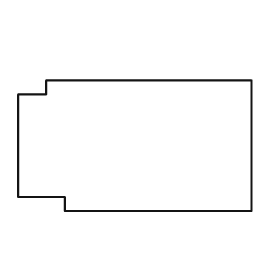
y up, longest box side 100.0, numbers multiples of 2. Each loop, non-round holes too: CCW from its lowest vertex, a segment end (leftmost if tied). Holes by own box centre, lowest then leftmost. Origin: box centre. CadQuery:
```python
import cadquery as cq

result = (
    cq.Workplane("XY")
    .moveTo(-30.0, -28.0)
    .lineTo(50.0, -28.0)
    .lineTo(50.0, 28.0)
    .lineTo(-38.0, 28.0)
    .lineTo(-38.0, 22.0)
    .lineTo(-50.0, 22.0)
    .lineTo(-50.0, -22.0)
    .lineTo(-30.0, -22.0)
    .close()
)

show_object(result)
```